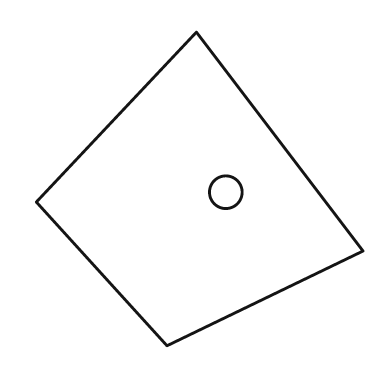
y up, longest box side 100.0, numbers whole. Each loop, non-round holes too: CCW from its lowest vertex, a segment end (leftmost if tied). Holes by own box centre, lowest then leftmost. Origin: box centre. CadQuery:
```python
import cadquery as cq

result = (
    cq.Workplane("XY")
    .moveTo(-10.0, -48.0)
    .lineTo(50.0, -19.0)
    .lineTo(-1.0, 48.0)
    .lineTo(-50.0, -4.0)
    .close()
    .moveTo(8.0, -1.0)
    .circle(5.0)
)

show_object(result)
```